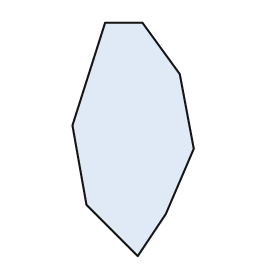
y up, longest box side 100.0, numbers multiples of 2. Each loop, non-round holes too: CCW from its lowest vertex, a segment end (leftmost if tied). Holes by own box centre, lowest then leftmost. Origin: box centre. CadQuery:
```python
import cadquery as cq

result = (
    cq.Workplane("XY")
    .moveTo(2.0, -50.0)
    .lineTo(14.0, -32.0)
    .lineTo(26.0, -4.0)
    .lineTo(20.0, 28.0)
    .lineTo(4.0, 50.0)
    .lineTo(-12.0, 50.0)
    .lineTo(-26.0, 6.0)
    .lineTo(-20.0, -28.0)
    .close()
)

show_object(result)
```